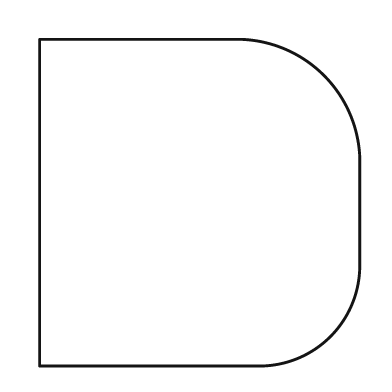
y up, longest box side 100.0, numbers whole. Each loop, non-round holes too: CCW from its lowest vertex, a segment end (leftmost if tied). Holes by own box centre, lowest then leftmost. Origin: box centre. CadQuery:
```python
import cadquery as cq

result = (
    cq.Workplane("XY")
    .moveTo(-49.0, -50.0)
    .lineTo(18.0, -50.0)
    .threePointArc((40.0, -41.0), (49.0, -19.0))
    .lineTo(49.0, 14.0)
    .threePointArc((38.0, 39.0), (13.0, 50.0))
    .lineTo(-49.0, 50.0)
    .close()
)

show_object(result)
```